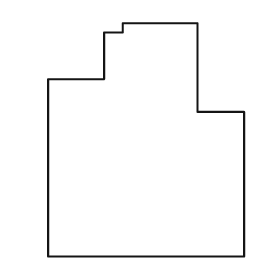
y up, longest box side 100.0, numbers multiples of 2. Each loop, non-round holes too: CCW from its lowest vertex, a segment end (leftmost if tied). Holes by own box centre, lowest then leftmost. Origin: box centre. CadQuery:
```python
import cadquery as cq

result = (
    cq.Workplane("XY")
    .moveTo(-42.0, -50.0)
    .lineTo(42.0, -50.0)
    .lineTo(42.0, 12.0)
    .lineTo(22.0, 12.0)
    .lineTo(22.0, 50.0)
    .lineTo(-10.0, 50.0)
    .lineTo(-10.0, 46.0)
    .lineTo(-18.0, 46.0)
    .lineTo(-18.0, 26.0)
    .lineTo(-42.0, 26.0)
    .close()
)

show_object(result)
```